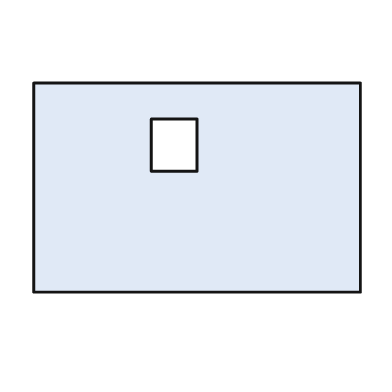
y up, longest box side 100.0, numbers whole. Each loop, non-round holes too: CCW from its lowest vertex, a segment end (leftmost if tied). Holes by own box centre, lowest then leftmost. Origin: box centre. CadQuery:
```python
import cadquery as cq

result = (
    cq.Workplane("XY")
    .moveTo(-50.0, -32.0)
    .lineTo(50.0, -32.0)
    .lineTo(50.0, 32.0)
    .lineTo(-50.0, 32.0)
    .close()
    .moveTo(-14.0, 5.0)
    .lineTo(0.0, 5.0)
    .lineTo(0.0, 21.0)
    .lineTo(-14.0, 21.0)
    .close()
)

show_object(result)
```